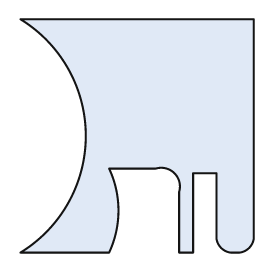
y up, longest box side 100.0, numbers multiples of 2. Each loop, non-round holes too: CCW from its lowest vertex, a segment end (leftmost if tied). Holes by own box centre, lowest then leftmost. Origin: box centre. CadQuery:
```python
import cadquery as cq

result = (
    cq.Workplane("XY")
    .moveTo(-50.0, -50.0)
    .lineTo(-12.0, -50.0)
    .threePointArc((-8.0, -32.0), (-12.0, -14.0))
    .lineTo(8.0, -14.0)
    .threePointArc((16.0, -16.0), (18.0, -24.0))
    .lineTo(18.0, -50.0)
    .lineTo(24.0, -50.0)
    .lineTo(24.0, -16.0)
    .lineTo(34.0, -16.0)
    .lineTo(34.0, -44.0)
    .threePointArc((36.0, -48.0), (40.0, -50.0))
    .lineTo(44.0, -50.0)
    .threePointArc((48.0, -48.0), (50.0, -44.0))
    .lineTo(50.0, 50.0)
    .lineTo(-50.0, 50.0)
    .threePointArc((-22.0, 0.0), (-50.0, -50.0))
    .close()
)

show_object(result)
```